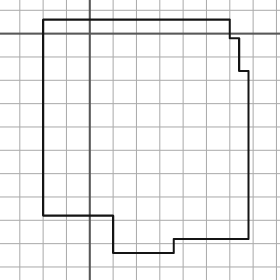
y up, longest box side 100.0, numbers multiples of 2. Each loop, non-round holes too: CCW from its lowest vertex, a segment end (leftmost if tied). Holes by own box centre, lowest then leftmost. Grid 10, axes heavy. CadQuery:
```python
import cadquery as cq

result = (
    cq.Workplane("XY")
    .moveTo(10.0, -94.0)
    .lineTo(36.0, -94.0)
    .lineTo(36.0, -88.0)
    .lineTo(68.0, -88.0)
    .lineTo(68.0, -16.0)
    .lineTo(64.0, -16.0)
    .lineTo(64.0, -2.0)
    .lineTo(60.0, -2.0)
    .lineTo(60.0, 6.0)
    .lineTo(-20.0, 6.0)
    .lineTo(-20.0, -78.0)
    .lineTo(10.0, -78.0)
    .close()
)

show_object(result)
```